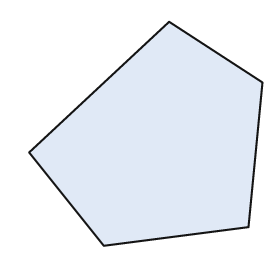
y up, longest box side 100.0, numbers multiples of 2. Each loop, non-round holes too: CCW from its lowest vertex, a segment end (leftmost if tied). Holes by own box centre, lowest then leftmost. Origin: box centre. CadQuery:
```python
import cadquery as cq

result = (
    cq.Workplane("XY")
    .moveTo(-18.0, -48.0)
    .lineTo(44.0, -40.0)
    .lineTo(50.0, 22.0)
    .lineTo(10.0, 48.0)
    .lineTo(-50.0, -8.0)
    .close()
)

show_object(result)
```